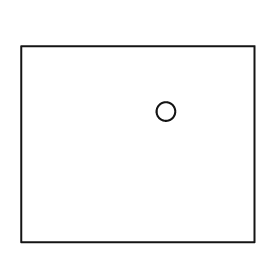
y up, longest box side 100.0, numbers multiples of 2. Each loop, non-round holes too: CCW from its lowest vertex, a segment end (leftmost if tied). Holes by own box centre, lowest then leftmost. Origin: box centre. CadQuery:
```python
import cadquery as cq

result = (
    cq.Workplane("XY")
    .moveTo(-50.0, -42.0)
    .lineTo(50.0, -42.0)
    .lineTo(50.0, 42.0)
    .lineTo(-50.0, 42.0)
    .close()
    .moveTo(12.0, 14.0)
    .circle(4.0)
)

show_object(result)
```